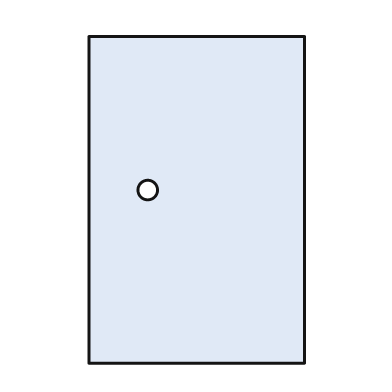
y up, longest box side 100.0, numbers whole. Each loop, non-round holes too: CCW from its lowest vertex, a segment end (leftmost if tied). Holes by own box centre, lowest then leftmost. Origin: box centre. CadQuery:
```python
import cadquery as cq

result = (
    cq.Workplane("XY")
    .moveTo(-33.0, -50.0)
    .lineTo(33.0, -50.0)
    .lineTo(33.0, 50.0)
    .lineTo(-33.0, 50.0)
    .close()
    .moveTo(-15.0, 3.0)
    .circle(3.0)
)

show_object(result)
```